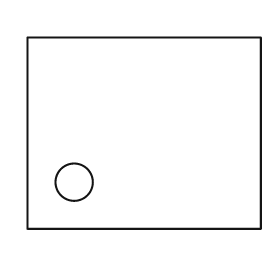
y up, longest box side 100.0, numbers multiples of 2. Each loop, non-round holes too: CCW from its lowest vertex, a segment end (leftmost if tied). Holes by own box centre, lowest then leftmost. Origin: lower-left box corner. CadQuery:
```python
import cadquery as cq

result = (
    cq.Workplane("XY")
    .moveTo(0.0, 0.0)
    .lineTo(100.0, 0.0)
    .lineTo(100.0, 82.0)
    .lineTo(0.0, 82.0)
    .close()
    .moveTo(20.0, 20.0)
    .circle(8.0)
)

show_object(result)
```